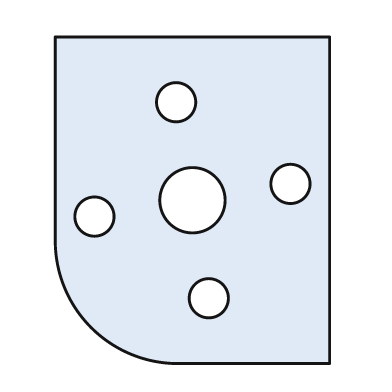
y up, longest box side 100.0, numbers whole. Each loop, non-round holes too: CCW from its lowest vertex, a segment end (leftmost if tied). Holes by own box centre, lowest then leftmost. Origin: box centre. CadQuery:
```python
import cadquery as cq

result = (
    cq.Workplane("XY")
    .moveTo(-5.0, -50.0)
    .lineTo(42.0, -50.0)
    .lineTo(42.0, 50.0)
    .lineTo(-42.0, 50.0)
    .lineTo(-42.0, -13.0)
    .threePointArc((-31.0, -39.0), (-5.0, -50.0))
    .close()
    .moveTo(5.0, -30.0)
    .circle(6.0)
    .moveTo(-30.0, -5.0)
    .circle(6.0)
    .moveTo(0.0, 0.0)
    .circle(10.0)
    .moveTo(30.0, 5.0)
    .circle(6.0)
    .moveTo(-5.0, 30.0)
    .circle(6.0)
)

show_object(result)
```